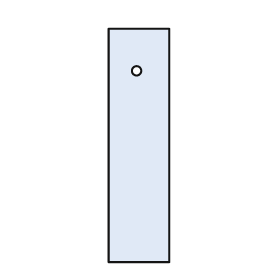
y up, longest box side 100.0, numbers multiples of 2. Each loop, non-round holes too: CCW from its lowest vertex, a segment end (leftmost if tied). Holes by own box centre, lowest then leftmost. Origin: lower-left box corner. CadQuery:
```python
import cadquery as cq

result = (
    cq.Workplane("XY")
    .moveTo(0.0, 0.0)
    .lineTo(26.0, 0.0)
    .lineTo(26.0, 100.0)
    .lineTo(0.0, 100.0)
    .close()
    .moveTo(12.0, 82.0)
    .circle(2.0)
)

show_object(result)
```